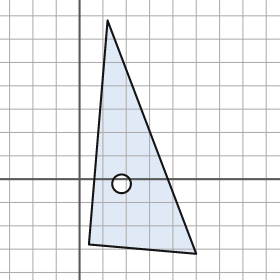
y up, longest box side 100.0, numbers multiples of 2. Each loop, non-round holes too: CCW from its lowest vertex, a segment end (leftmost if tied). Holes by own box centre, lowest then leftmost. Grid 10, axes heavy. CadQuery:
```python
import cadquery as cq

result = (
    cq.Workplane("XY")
    .moveTo(50.0, -32.0)
    .lineTo(12.0, 68.0)
    .lineTo(4.0, -28.0)
    .close()
    .moveTo(18.0, -2.0)
    .circle(4.0)
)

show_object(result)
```